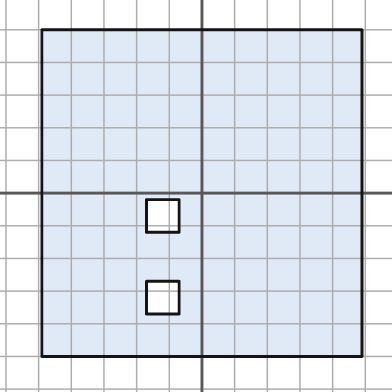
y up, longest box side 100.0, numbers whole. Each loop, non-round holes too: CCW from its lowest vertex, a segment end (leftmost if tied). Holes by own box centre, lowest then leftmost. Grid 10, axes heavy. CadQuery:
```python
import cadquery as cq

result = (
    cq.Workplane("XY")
    .moveTo(-49.0, -50.0)
    .lineTo(49.0, -50.0)
    .lineTo(49.0, 50.0)
    .lineTo(-49.0, 50.0)
    .close()
    .moveTo(-17.0, -37.0)
    .lineTo(-7.0, -37.0)
    .lineTo(-7.0, -27.0)
    .lineTo(-17.0, -27.0)
    .close()
    .moveTo(-17.0, -12.0)
    .lineTo(-7.0, -12.0)
    .lineTo(-7.0, -2.0)
    .lineTo(-17.0, -2.0)
    .close()
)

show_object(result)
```